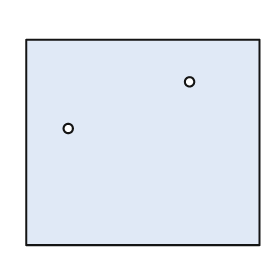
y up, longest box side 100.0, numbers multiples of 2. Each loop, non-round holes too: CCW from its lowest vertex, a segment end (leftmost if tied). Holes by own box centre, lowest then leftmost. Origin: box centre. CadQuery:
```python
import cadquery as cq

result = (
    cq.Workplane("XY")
    .moveTo(-50.0, -44.0)
    .lineTo(50.0, -44.0)
    .lineTo(50.0, 44.0)
    .lineTo(-50.0, 44.0)
    .close()
    .moveTo(-32.0, 6.0)
    .circle(2.0)
    .moveTo(20.0, 26.0)
    .circle(2.0)
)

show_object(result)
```